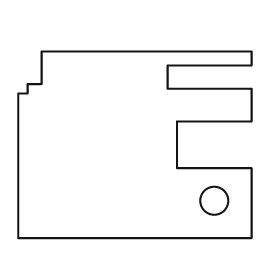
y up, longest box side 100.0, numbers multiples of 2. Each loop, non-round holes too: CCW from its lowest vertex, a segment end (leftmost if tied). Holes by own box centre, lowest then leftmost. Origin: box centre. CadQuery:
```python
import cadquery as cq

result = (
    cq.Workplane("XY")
    .moveTo(-50.0, -40.0)
    .lineTo(50.0, -40.0)
    .lineTo(50.0, -10.0)
    .lineTo(18.0, -10.0)
    .lineTo(18.0, 10.0)
    .lineTo(50.0, 10.0)
    .lineTo(50.0, 24.0)
    .lineTo(14.0, 24.0)
    .lineTo(14.0, 34.0)
    .lineTo(50.0, 34.0)
    .lineTo(50.0, 40.0)
    .lineTo(-40.0, 40.0)
    .lineTo(-40.0, 26.0)
    .lineTo(-46.0, 26.0)
    .lineTo(-46.0, 22.0)
    .lineTo(-50.0, 22.0)
    .close()
    .moveTo(34.0, -24.0)
    .circle(6.0)
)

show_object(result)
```